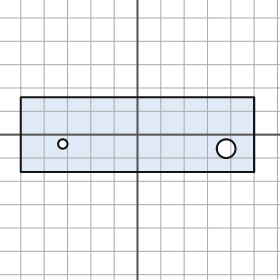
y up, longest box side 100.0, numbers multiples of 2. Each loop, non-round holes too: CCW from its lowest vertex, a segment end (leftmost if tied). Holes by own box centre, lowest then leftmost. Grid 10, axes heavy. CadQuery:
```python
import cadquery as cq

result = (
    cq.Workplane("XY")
    .moveTo(-50.0, -16.0)
    .lineTo(50.0, -16.0)
    .lineTo(50.0, 16.0)
    .lineTo(-50.0, 16.0)
    .close()
    .moveTo(38.0, -6.0)
    .circle(4.0)
    .moveTo(-32.0, -4.0)
    .circle(2.0)
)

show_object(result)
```